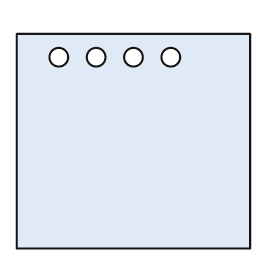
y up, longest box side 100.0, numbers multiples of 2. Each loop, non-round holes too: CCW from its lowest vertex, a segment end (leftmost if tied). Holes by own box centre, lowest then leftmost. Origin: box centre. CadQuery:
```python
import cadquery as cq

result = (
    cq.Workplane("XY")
    .moveTo(-50.0, -46.0)
    .lineTo(50.0, -46.0)
    .lineTo(50.0, 46.0)
    .lineTo(-50.0, 46.0)
    .close()
    .moveTo(-32.0, 36.0)
    .circle(4.0)
    .moveTo(-16.0, 36.0)
    .circle(4.0)
    .moveTo(0.0, 36.0)
    .circle(4.0)
    .moveTo(16.0, 36.0)
    .circle(4.0)
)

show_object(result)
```